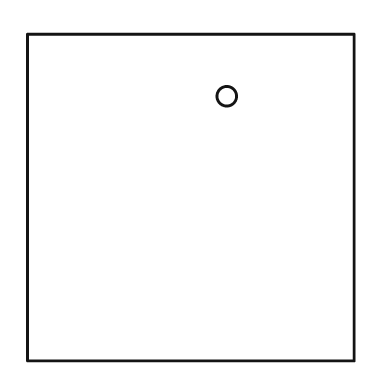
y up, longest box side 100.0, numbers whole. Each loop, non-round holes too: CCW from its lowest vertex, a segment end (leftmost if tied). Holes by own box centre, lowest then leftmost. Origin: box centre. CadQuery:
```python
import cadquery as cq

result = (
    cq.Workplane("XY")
    .moveTo(-50.0, -50.0)
    .lineTo(50.0, -50.0)
    .lineTo(50.0, 50.0)
    .lineTo(-50.0, 50.0)
    .close()
    .moveTo(11.0, 31.0)
    .circle(3.0)
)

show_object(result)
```